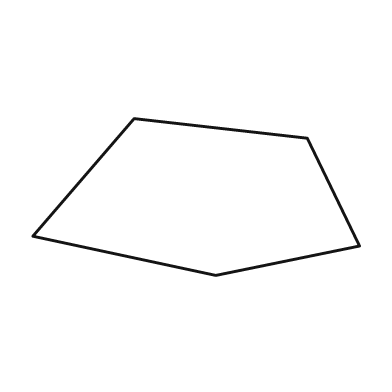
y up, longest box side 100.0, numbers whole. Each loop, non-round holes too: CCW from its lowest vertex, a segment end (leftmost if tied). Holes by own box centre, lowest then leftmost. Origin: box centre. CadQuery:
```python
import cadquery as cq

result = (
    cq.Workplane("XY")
    .moveTo(6.0, -24.0)
    .lineTo(50.0, -15.0)
    .lineTo(34.0, 18.0)
    .lineTo(-19.0, 24.0)
    .lineTo(-50.0, -12.0)
    .close()
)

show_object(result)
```